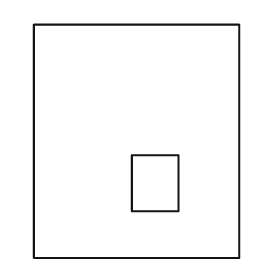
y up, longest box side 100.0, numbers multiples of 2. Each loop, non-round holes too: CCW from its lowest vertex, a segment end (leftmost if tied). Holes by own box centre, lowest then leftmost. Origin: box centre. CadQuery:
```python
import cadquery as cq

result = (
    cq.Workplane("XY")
    .moveTo(-44.0, -50.0)
    .lineTo(44.0, -50.0)
    .lineTo(44.0, 50.0)
    .lineTo(-44.0, 50.0)
    .close()
    .moveTo(-2.0, -30.0)
    .lineTo(18.0, -30.0)
    .lineTo(18.0, -6.0)
    .lineTo(-2.0, -6.0)
    .close()
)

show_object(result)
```